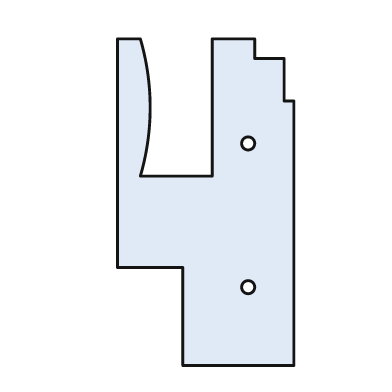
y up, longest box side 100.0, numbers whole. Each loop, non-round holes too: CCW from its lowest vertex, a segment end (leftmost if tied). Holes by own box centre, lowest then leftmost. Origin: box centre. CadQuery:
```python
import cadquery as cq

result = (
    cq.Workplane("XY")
    .moveTo(-7.0, -50.0)
    .lineTo(27.0, -50.0)
    .lineTo(27.0, 31.0)
    .lineTo(24.0, 31.0)
    .lineTo(24.0, 44.0)
    .lineTo(15.0, 44.0)
    .lineTo(15.0, 50.0)
    .lineTo(2.0, 50.0)
    .lineTo(2.0, 8.0)
    .lineTo(-20.0, 8.0)
    .threePointArc((-17.0, 29.0), (-20.0, 50.0))
    .lineTo(-27.0, 50.0)
    .lineTo(-27.0, -20.0)
    .lineTo(-7.0, -20.0)
    .close()
    .moveTo(13.0, -26.0)
    .circle(2.0)
    .moveTo(13.0, 18.0)
    .circle(2.0)
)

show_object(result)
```